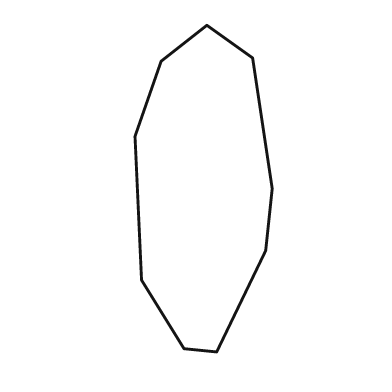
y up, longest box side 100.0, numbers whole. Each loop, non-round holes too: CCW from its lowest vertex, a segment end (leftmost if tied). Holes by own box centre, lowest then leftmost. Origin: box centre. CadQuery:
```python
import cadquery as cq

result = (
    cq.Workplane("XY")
    .moveTo(4.0, -50.0)
    .lineTo(19.0, -19.0)
    .lineTo(21.0, 0.0)
    .lineTo(15.0, 40.0)
    .lineTo(1.0, 50.0)
    .lineTo(-13.0, 39.0)
    .lineTo(-21.0, 16.0)
    .lineTo(-19.0, -28.0)
    .lineTo(-6.0, -49.0)
    .close()
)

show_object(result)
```